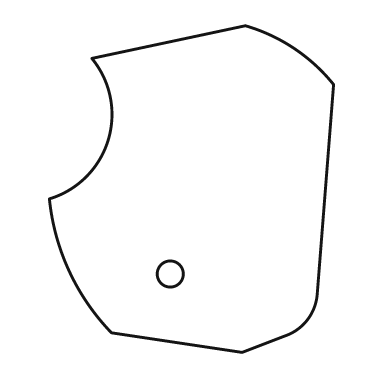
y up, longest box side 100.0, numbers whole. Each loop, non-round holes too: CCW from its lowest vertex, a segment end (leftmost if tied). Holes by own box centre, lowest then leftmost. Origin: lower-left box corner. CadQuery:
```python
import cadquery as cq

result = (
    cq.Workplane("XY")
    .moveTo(59.0, 0.0)
    .lineTo(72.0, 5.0)
    .threePointArc((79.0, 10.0), (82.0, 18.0))
    .lineTo(87.0, 82.0)
    .threePointArc((75.0, 93.0), (60.0, 100.0))
    .lineTo(13.0, 90.0)
    .threePointArc((18.0, 65.0), (0.0, 47.0))
    .threePointArc((6.0, 25.0), (19.0, 6.0))
    .close()
    .moveTo(37.0, 24.0)
    .circle(4.0)
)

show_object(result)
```